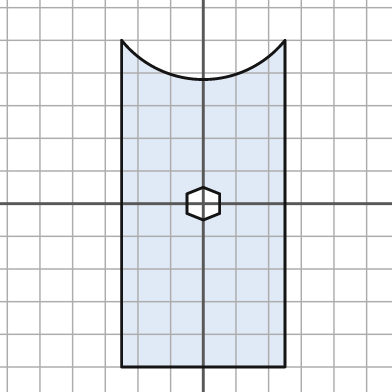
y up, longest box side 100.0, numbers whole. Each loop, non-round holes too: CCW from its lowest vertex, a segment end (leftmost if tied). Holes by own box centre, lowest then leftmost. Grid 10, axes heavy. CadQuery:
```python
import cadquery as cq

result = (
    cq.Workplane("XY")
    .moveTo(-25.0, -50.0)
    .lineTo(25.0, -50.0)
    .lineTo(25.0, 50.0)
    .threePointArc((0.0, 38.0), (-25.0, 50.0))
    .close()
    .moveTo(0.0, -5.0)
    .lineTo(5.0, -3.0)
    .lineTo(5.0, 3.0)
    .lineTo(0.0, 5.0)
    .lineTo(-5.0, 3.0)
    .lineTo(-5.0, -3.0)
    .close()
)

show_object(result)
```